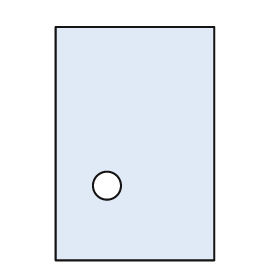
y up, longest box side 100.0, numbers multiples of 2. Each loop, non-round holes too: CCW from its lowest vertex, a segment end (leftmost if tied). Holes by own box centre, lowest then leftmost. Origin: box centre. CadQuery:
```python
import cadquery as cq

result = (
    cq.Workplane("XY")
    .moveTo(-34.0, -50.0)
    .lineTo(34.0, -50.0)
    .lineTo(34.0, 50.0)
    .lineTo(-34.0, 50.0)
    .close()
    .moveTo(-12.0, -18.0)
    .circle(6.0)
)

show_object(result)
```